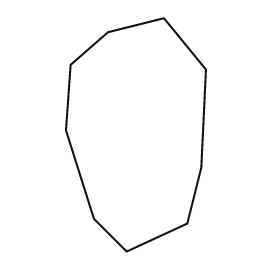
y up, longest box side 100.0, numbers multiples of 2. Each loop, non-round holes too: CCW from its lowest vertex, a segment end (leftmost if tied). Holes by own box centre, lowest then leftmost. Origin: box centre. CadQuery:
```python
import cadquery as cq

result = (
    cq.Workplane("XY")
    .moveTo(-4.0, -50.0)
    .lineTo(22.0, -38.0)
    .lineTo(28.0, -14.0)
    .lineTo(30.0, 28.0)
    .lineTo(12.0, 50.0)
    .lineTo(-12.0, 44.0)
    .lineTo(-28.0, 30.0)
    .lineTo(-30.0, 2.0)
    .lineTo(-18.0, -36.0)
    .close()
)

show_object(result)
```